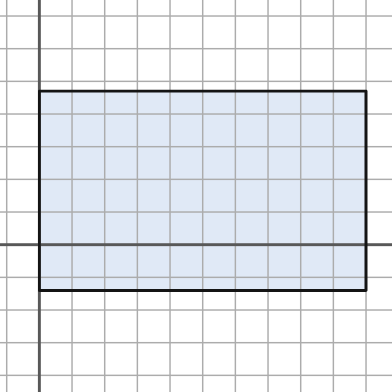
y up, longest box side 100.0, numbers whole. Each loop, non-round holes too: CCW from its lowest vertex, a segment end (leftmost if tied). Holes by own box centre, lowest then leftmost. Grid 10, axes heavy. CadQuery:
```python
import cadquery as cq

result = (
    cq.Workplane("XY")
    .moveTo(0.0, -14.0)
    .lineTo(100.0, -14.0)
    .lineTo(100.0, 47.0)
    .lineTo(0.0, 47.0)
    .close()
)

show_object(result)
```